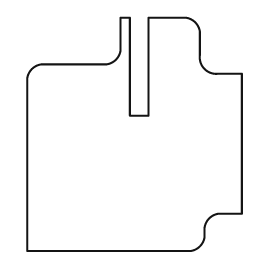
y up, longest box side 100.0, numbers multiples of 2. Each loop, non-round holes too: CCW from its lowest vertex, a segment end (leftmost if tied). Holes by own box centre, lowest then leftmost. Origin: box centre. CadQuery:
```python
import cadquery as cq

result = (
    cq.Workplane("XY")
    .moveTo(-46.0, -50.0)
    .lineTo(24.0, -50.0)
    .threePointArc((28.0, -48.0), (30.0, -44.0))
    .lineTo(30.0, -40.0)
    .threePointArc((32.0, -36.0), (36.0, -34.0))
    .lineTo(46.0, -34.0)
    .lineTo(46.0, 26.0)
    .lineTo(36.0, 26.0)
    .threePointArc((30.0, 28.0), (28.0, 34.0))
    .lineTo(28.0, 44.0)
    .threePointArc((26.0, 48.0), (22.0, 50.0))
    .lineTo(6.0, 50.0)
    .lineTo(6.0, 8.0)
    .lineTo(-2.0, 8.0)
    .lineTo(-2.0, 50.0)
    .lineTo(-6.0, 50.0)
    .lineTo(-6.0, 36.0)
    .threePointArc((-8.0, 32.0), (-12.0, 30.0))
    .lineTo(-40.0, 30.0)
    .threePointArc((-44.0, 28.0), (-46.0, 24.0))
    .close()
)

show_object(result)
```